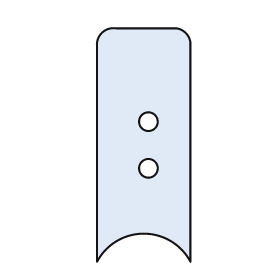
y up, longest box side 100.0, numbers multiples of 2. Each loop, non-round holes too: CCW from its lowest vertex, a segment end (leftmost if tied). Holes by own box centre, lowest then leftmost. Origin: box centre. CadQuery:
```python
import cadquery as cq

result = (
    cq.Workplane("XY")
    .moveTo(-20.0, -50.0)
    .threePointArc((0.0, -38.0), (20.0, -50.0))
    .lineTo(20.0, 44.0)
    .threePointArc((18.0, 48.0), (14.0, 50.0))
    .lineTo(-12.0, 50.0)
    .threePointArc((-18.0, 48.0), (-20.0, 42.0))
    .close()
    .moveTo(2.0, -10.0)
    .circle(4.0)
    .moveTo(2.0, 10.0)
    .circle(4.0)
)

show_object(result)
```